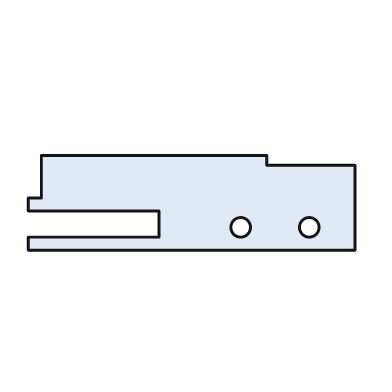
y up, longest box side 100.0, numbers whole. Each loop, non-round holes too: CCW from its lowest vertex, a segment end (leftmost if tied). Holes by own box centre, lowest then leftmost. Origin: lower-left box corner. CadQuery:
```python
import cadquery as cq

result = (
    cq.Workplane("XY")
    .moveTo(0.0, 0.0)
    .lineTo(100.0, 0.0)
    .lineTo(100.0, 26.0)
    .lineTo(73.0, 26.0)
    .lineTo(73.0, 29.0)
    .lineTo(4.0, 29.0)
    .lineTo(4.0, 16.0)
    .lineTo(0.0, 16.0)
    .lineTo(0.0, 12.0)
    .lineTo(40.0, 12.0)
    .lineTo(40.0, 4.0)
    .lineTo(0.0, 4.0)
    .close()
    .moveTo(65.0, 7.0)
    .circle(3.0)
    .moveTo(86.0, 7.0)
    .circle(3.0)
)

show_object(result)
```